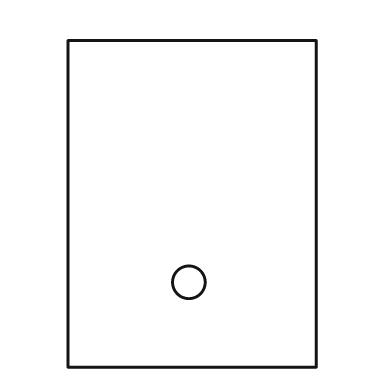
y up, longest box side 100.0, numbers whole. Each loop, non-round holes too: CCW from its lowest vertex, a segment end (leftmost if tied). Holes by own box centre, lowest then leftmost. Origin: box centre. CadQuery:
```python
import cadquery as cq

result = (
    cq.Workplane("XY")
    .moveTo(-38.0, -50.0)
    .lineTo(38.0, -50.0)
    .lineTo(38.0, 50.0)
    .lineTo(-38.0, 50.0)
    .close()
    .moveTo(-1.0, -24.0)
    .circle(5.0)
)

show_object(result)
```